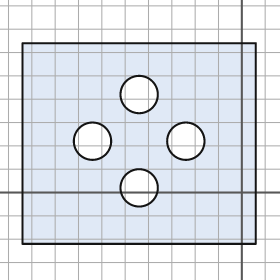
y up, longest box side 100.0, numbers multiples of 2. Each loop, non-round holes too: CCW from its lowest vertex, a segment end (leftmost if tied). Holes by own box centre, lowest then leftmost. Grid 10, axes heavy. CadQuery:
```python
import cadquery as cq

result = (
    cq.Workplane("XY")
    .moveTo(-94.0, -22.0)
    .lineTo(6.0, -22.0)
    .lineTo(6.0, 64.0)
    .lineTo(-94.0, 64.0)
    .close()
    .moveTo(-44.0, 2.0)
    .circle(8.0)
    .moveTo(-64.0, 22.0)
    .circle(8.0)
    .moveTo(-24.0, 22.0)
    .circle(8.0)
    .moveTo(-44.0, 42.0)
    .circle(8.0)
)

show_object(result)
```